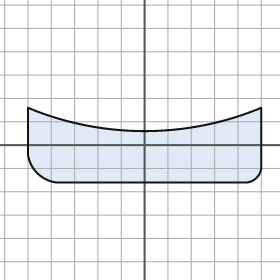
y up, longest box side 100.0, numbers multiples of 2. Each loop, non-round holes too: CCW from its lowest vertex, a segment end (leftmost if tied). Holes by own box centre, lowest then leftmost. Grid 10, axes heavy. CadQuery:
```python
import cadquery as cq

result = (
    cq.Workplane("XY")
    .moveTo(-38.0, -16.0)
    .lineTo(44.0, -16.0)
    .threePointArc((48.0, -14.0), (50.0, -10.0))
    .lineTo(50.0, 16.0)
    .threePointArc((0.0, 6.0), (-50.0, 16.0))
    .lineTo(-50.0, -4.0)
    .threePointArc((-46.0, -12.0), (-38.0, -16.0))
    .close()
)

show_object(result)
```